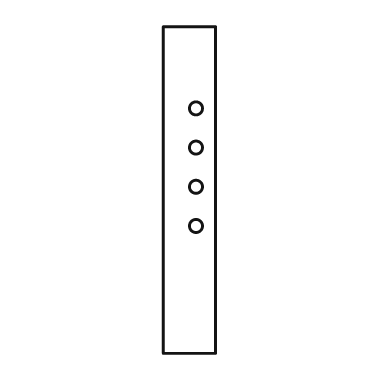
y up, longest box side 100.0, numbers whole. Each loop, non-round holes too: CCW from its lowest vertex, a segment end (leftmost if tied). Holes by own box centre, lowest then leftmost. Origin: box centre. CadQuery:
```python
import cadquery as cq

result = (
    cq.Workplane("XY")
    .moveTo(-8.0, -50.0)
    .lineTo(8.0, -50.0)
    .lineTo(8.0, 50.0)
    .lineTo(-8.0, 50.0)
    .close()
    .moveTo(2.0, -11.0)
    .circle(2.0)
    .moveTo(2.0, 1.0)
    .circle(2.0)
    .moveTo(2.0, 13.0)
    .circle(2.0)
    .moveTo(2.0, 25.0)
    .circle(2.0)
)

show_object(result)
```